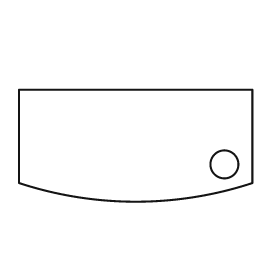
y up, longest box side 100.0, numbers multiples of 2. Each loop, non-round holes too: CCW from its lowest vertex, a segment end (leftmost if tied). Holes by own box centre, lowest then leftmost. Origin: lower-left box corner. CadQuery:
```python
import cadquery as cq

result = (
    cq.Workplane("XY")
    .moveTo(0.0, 8.0)
    .threePointArc((50.0, 0.0), (100.0, 8.0))
    .lineTo(100.0, 48.0)
    .lineTo(0.0, 48.0)
    .close()
    .moveTo(88.0, 16.0)
    .circle(6.0)
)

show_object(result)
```